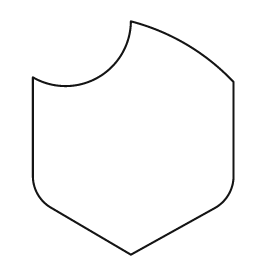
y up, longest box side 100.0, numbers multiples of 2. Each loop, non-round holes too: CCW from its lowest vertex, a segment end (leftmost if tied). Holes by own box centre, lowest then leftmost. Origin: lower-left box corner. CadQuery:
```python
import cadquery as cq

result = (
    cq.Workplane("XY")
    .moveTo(42.0, 0.0)
    .lineTo(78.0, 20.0)
    .threePointArc((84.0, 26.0), (86.0, 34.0))
    .lineTo(86.0, 74.0)
    .threePointArc((66.0, 90.0), (42.0, 100.0))
    .threePointArc((28.0, 76.0), (0.0, 76.0))
    .lineTo(0.0, 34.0)
    .threePointArc((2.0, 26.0), (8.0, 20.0))
    .close()
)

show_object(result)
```